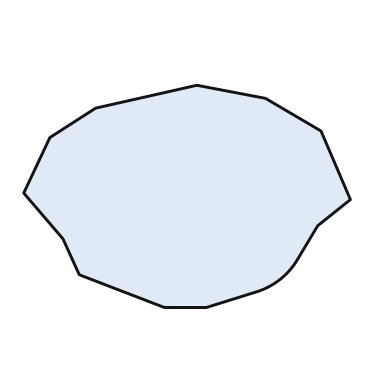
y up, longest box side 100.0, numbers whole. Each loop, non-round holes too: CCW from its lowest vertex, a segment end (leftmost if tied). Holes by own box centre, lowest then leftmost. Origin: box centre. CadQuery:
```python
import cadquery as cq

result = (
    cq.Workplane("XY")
    .moveTo(-7.0, -34.0)
    .lineTo(6.0, -34.0)
    .lineTo(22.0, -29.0)
    .threePointArc((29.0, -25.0), (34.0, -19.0))
    .lineTo(40.0, -9.0)
    .lineTo(50.0, -1.0)
    .lineTo(41.0, 20.0)
    .lineTo(24.0, 30.0)
    .lineTo(3.0, 34.0)
    .lineTo(-28.0, 27.0)
    .lineTo(-42.0, 18.0)
    .lineTo(-50.0, 1.0)
    .lineTo(-38.0, -13.0)
    .lineTo(-33.0, -24.0)
    .close()
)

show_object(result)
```